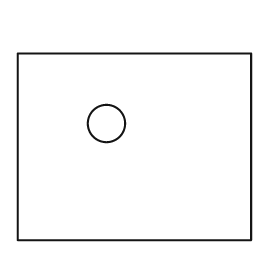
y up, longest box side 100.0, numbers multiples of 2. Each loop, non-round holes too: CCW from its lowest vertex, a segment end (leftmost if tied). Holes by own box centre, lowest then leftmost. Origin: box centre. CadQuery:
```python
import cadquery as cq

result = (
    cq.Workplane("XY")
    .moveTo(-50.0, -40.0)
    .lineTo(50.0, -40.0)
    .lineTo(50.0, 40.0)
    .lineTo(-50.0, 40.0)
    .close()
    .moveTo(-12.0, 10.0)
    .circle(8.0)
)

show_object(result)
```